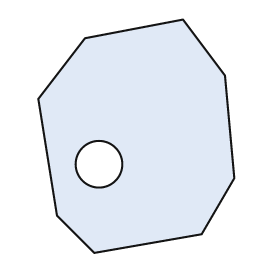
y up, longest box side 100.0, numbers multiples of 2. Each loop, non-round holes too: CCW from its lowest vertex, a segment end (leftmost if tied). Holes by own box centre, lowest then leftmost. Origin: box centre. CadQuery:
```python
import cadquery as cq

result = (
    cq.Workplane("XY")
    .moveTo(-18.0, -50.0)
    .lineTo(28.0, -42.0)
    .lineTo(42.0, -18.0)
    .lineTo(38.0, 26.0)
    .lineTo(20.0, 50.0)
    .lineTo(-22.0, 42.0)
    .lineTo(-42.0, 16.0)
    .lineTo(-34.0, -34.0)
    .close()
    .moveTo(-16.0, -12.0)
    .circle(10.0)
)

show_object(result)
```